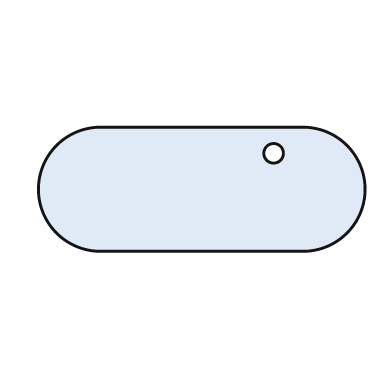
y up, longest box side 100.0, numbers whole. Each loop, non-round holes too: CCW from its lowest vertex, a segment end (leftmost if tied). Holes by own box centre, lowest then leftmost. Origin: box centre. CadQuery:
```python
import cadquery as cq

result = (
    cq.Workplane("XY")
    .moveTo(-31.0, -19.0)
    .lineTo(31.0, -19.0)
    .threePointArc((50.0, 0.0), (31.0, 19.0))
    .lineTo(-31.0, 19.0)
    .threePointArc((-50.0, 0.0), (-31.0, -19.0))
    .close()
    .moveTo(22.0, 11.0)
    .circle(3.0)
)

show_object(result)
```